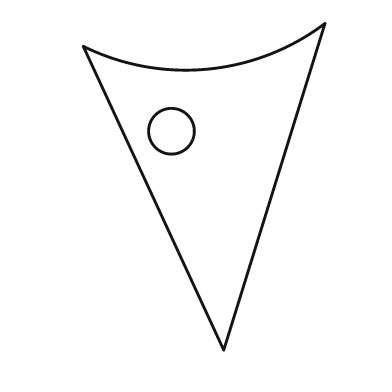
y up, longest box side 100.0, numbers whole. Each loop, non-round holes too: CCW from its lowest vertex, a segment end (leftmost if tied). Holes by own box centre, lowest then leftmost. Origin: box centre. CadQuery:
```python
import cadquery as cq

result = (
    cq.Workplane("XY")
    .moveTo(6.0, -50.0)
    .lineTo(37.0, 50.0)
    .threePointArc((1.0, 36.0), (-37.0, 43.0))
    .close()
    .moveTo(-10.0, 17.0)
    .circle(7.0)
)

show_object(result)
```